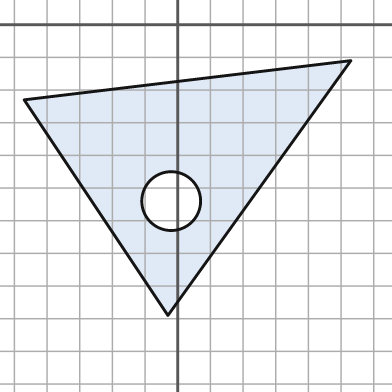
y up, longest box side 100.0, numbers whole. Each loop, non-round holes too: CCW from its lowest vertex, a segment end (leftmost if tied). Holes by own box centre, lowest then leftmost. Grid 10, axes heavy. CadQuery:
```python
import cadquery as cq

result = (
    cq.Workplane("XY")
    .moveTo(-3.0, -89.0)
    .lineTo(53.0, -11.0)
    .lineTo(-47.0, -23.0)
    .close()
    .moveTo(-2.0, -54.0)
    .circle(9.0)
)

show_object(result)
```